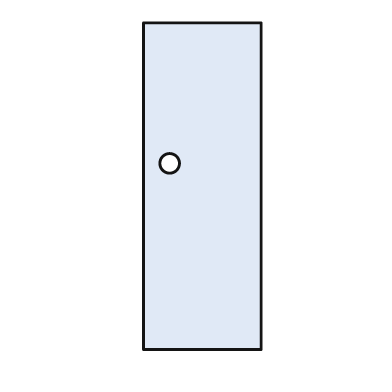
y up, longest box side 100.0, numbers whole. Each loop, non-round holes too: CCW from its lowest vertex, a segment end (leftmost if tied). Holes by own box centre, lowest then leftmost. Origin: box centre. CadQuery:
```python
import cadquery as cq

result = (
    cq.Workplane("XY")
    .moveTo(-18.0, -50.0)
    .lineTo(18.0, -50.0)
    .lineTo(18.0, 50.0)
    .lineTo(-18.0, 50.0)
    .close()
    .moveTo(-10.0, 7.0)
    .circle(3.0)
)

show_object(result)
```